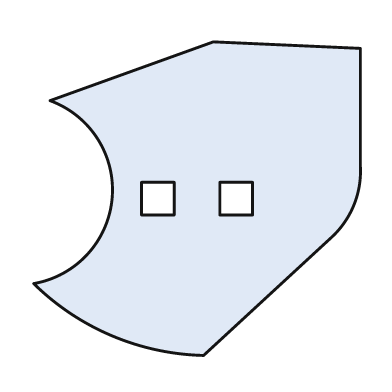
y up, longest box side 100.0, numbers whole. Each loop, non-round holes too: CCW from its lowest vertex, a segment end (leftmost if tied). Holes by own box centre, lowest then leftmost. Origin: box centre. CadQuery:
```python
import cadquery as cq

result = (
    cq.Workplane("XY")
    .moveTo(2.0, -48.0)
    .lineTo(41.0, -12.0)
    .threePointArc((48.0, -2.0), (50.0, 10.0))
    .lineTo(50.0, 46.0)
    .lineTo(5.0, 48.0)
    .lineTo(-45.0, 30.0)
    .threePointArc((-26.0, 0.0), (-50.0, -26.0))
    .threePointArc((-26.0, -42.0), (2.0, -48.0))
    .close()
    .moveTo(-17.0, -5.0)
    .lineTo(-7.0, -5.0)
    .lineTo(-7.0, 5.0)
    .lineTo(-17.0, 5.0)
    .close()
    .moveTo(7.0, -5.0)
    .lineTo(17.0, -5.0)
    .lineTo(17.0, 5.0)
    .lineTo(7.0, 5.0)
    .close()
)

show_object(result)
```